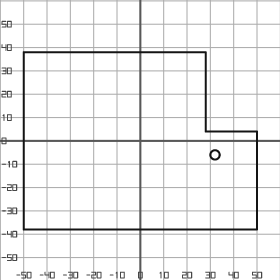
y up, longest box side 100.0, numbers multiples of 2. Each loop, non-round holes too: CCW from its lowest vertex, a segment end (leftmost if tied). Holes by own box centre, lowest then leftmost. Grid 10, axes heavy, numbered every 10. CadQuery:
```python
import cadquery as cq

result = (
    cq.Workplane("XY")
    .moveTo(-50.0, -38.0)
    .lineTo(50.0, -38.0)
    .lineTo(50.0, 4.0)
    .lineTo(28.0, 4.0)
    .lineTo(28.0, 38.0)
    .lineTo(-50.0, 38.0)
    .close()
    .moveTo(32.0, -6.0)
    .circle(2.0)
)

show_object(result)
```